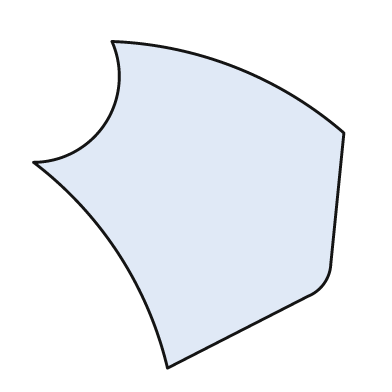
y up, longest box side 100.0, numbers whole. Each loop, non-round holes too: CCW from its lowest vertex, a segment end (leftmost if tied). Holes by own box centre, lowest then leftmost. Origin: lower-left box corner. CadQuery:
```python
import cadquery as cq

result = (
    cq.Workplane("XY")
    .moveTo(41.0, 0.0)
    .lineTo(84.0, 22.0)
    .threePointArc((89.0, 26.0), (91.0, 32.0))
    .lineTo(95.0, 72.0)
    .threePointArc((62.0, 92.0), (24.0, 100.0))
    .threePointArc((22.0, 75.0), (0.0, 63.0))
    .threePointArc((26.0, 35.0), (41.0, 0.0))
    .close()
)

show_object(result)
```